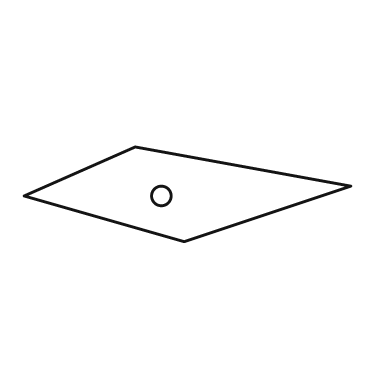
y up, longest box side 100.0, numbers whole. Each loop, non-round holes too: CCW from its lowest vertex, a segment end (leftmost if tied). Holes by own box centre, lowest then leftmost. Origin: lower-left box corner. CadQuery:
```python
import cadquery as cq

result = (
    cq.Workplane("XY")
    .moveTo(49.0, 0.0)
    .lineTo(100.0, 17.0)
    .lineTo(34.0, 29.0)
    .lineTo(0.0, 14.0)
    .close()
    .moveTo(42.0, 14.0)
    .circle(3.0)
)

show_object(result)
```